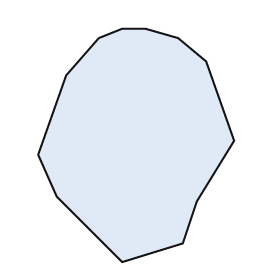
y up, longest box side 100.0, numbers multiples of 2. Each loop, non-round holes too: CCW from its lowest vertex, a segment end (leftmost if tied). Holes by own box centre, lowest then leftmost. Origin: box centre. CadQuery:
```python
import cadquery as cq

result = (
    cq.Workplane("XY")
    .moveTo(-6.0, -50.0)
    .lineTo(20.0, -42.0)
    .lineTo(26.0, -24.0)
    .lineTo(42.0, 2.0)
    .lineTo(30.0, 36.0)
    .lineTo(18.0, 46.0)
    .lineTo(4.0, 50.0)
    .lineTo(-6.0, 50.0)
    .lineTo(-16.0, 46.0)
    .lineTo(-30.0, 30.0)
    .lineTo(-42.0, -4.0)
    .lineTo(-34.0, -22.0)
    .close()
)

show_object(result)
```